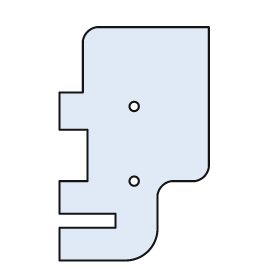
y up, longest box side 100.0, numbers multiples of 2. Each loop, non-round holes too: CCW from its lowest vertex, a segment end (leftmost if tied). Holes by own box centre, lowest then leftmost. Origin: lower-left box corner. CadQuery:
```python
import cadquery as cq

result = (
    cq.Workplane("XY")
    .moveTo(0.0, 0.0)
    .lineTo(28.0, 0.0)
    .threePointArc((38.0, 4.0), (42.0, 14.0))
    .lineTo(42.0, 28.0)
    .threePointArc((44.0, 32.0), (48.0, 34.0))
    .lineTo(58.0, 34.0)
    .threePointArc((62.0, 36.0), (64.0, 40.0))
    .lineTo(64.0, 100.0)
    .lineTo(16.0, 100.0)
    .threePointArc((12.0, 98.0), (10.0, 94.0))
    .lineTo(10.0, 72.0)
    .lineTo(0.0, 72.0)
    .lineTo(0.0, 56.0)
    .lineTo(12.0, 56.0)
    .lineTo(12.0, 34.0)
    .lineTo(0.0, 34.0)
    .lineTo(0.0, 20.0)
    .lineTo(24.0, 20.0)
    .lineTo(24.0, 14.0)
    .lineTo(0.0, 14.0)
    .close()
    .moveTo(32.0, 34.0)
    .circle(2.0)
    .moveTo(32.0, 66.0)
    .circle(2.0)
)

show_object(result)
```